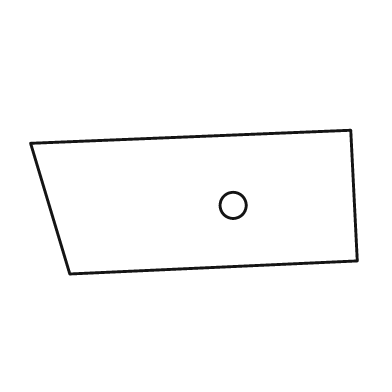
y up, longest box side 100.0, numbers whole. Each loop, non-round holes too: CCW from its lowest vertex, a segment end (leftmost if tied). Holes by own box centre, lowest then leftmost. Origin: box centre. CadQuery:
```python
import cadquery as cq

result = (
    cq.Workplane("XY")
    .moveTo(-38.0, -22.0)
    .lineTo(50.0, -18.0)
    .lineTo(48.0, 22.0)
    .lineTo(-50.0, 18.0)
    .close()
    .moveTo(12.0, -1.0)
    .circle(4.0)
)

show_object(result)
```